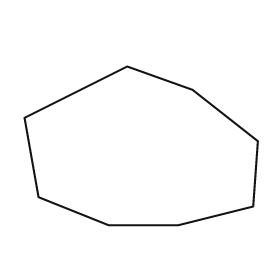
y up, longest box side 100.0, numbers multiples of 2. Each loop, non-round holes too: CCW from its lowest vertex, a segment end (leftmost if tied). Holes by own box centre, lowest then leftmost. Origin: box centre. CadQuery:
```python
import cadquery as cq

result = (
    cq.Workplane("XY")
    .moveTo(-14.0, -34.0)
    .lineTo(16.0, -34.0)
    .lineTo(48.0, -26.0)
    .lineTo(50.0, 2.0)
    .lineTo(22.0, 24.0)
    .lineTo(-6.0, 34.0)
    .lineTo(-50.0, 12.0)
    .lineTo(-44.0, -22.0)
    .close()
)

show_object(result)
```